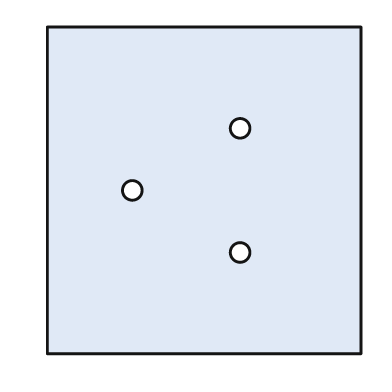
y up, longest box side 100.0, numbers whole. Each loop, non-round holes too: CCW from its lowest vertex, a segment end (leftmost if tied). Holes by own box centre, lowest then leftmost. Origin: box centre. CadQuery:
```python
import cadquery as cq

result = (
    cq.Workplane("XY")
    .moveTo(-48.0, -50.0)
    .lineTo(48.0, -50.0)
    .lineTo(48.0, 50.0)
    .lineTo(-48.0, 50.0)
    .close()
    .moveTo(11.0, -19.0)
    .circle(3.0)
    .moveTo(-22.0, 0.0)
    .circle(3.0)
    .moveTo(11.0, 19.0)
    .circle(3.0)
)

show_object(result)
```